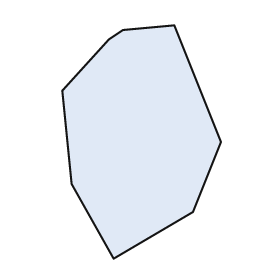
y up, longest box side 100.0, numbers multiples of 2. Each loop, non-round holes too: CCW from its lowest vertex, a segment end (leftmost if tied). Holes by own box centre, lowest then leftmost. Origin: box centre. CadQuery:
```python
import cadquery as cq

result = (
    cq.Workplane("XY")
    .moveTo(-12.0, -50.0)
    .lineTo(22.0, -30.0)
    .lineTo(34.0, 0.0)
    .lineTo(14.0, 50.0)
    .lineTo(-8.0, 48.0)
    .lineTo(-14.0, 44.0)
    .lineTo(-34.0, 22.0)
    .lineTo(-30.0, -18.0)
    .close()
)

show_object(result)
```